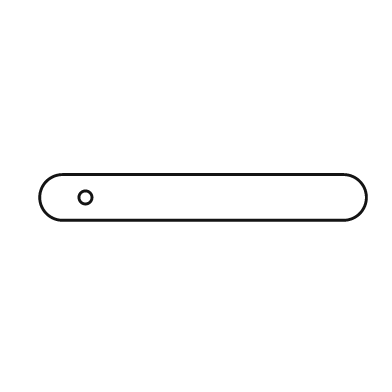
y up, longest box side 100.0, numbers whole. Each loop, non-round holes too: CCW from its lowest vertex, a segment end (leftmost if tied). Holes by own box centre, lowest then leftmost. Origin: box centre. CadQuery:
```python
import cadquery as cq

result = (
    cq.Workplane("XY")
    .moveTo(-43.0, -7.0)
    .lineTo(43.0, -7.0)
    .threePointArc((50.0, 0.0), (43.0, 7.0))
    .lineTo(-43.0, 7.0)
    .threePointArc((-50.0, 0.0), (-43.0, -7.0))
    .close()
    .moveTo(-36.0, 0.0)
    .circle(2.0)
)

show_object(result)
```